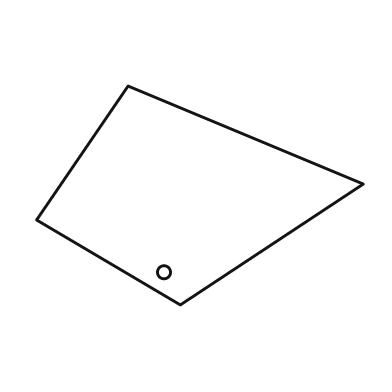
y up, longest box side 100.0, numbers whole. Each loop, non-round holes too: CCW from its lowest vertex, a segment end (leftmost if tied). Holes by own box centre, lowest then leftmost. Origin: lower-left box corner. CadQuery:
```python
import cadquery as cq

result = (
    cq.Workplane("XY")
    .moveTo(44.0, 0.0)
    .lineTo(100.0, 37.0)
    .lineTo(28.0, 67.0)
    .lineTo(0.0, 26.0)
    .close()
    .moveTo(39.0, 10.0)
    .circle(2.0)
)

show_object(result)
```